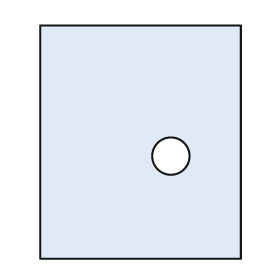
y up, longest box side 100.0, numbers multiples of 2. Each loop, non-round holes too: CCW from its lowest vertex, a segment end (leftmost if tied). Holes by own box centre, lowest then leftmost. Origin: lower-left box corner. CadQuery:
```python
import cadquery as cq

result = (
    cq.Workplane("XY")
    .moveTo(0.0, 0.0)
    .lineTo(86.0, 0.0)
    .lineTo(86.0, 100.0)
    .lineTo(0.0, 100.0)
    .close()
    .moveTo(56.0, 44.0)
    .circle(8.0)
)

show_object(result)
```